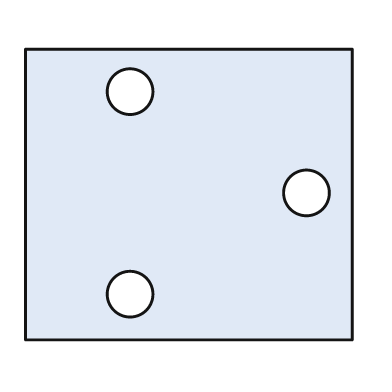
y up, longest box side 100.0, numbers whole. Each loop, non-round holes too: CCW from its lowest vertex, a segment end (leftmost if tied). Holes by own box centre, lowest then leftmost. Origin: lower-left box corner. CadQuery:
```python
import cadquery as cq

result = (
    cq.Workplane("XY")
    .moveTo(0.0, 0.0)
    .lineTo(100.0, 0.0)
    .lineTo(100.0, 89.0)
    .lineTo(0.0, 89.0)
    .close()
    .moveTo(32.0, 14.0)
    .circle(7.0)
    .moveTo(86.0, 45.0)
    .circle(7.0)
    .moveTo(32.0, 76.0)
    .circle(7.0)
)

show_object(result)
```